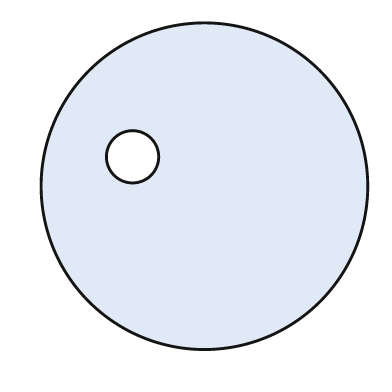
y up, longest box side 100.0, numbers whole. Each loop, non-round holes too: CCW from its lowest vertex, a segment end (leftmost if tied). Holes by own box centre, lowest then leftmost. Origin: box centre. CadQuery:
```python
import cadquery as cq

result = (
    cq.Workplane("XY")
    .moveTo(0.0, 0.0)
    .circle(50.0)
    .moveTo(-22.0, 9.0)
    .circle(8.0)
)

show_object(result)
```